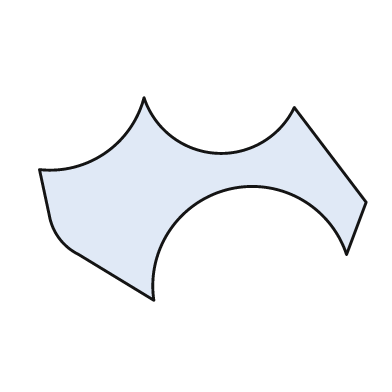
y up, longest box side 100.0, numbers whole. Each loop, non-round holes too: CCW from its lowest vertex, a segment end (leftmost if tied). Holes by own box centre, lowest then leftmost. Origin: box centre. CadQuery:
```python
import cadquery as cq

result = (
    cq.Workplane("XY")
    .moveTo(-15.0, -31.0)
    .threePointArc((8.0, 3.0), (44.0, -17.0))
    .lineTo(50.0, -1.0)
    .lineTo(28.0, 28.0)
    .threePointArc((4.0, 14.0), (-18.0, 31.0))
    .threePointArc((-30.0, 14.0), (-50.0, 9.0))
    .lineTo(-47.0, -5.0)
    .threePointArc((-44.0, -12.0), (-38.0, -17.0))
    .close()
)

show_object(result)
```